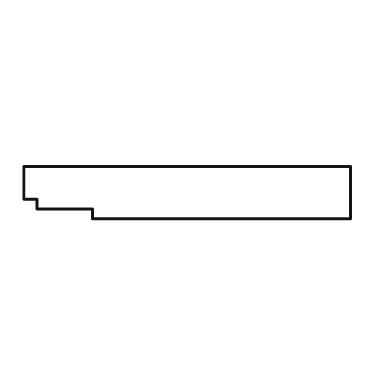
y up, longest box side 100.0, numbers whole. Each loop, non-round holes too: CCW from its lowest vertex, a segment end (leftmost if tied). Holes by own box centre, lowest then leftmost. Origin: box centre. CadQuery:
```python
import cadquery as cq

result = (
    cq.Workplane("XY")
    .moveTo(-29.0, -8.0)
    .lineTo(50.0, -8.0)
    .lineTo(50.0, 8.0)
    .lineTo(-50.0, 8.0)
    .lineTo(-50.0, -2.0)
    .lineTo(-46.0, -2.0)
    .lineTo(-46.0, -5.0)
    .lineTo(-29.0, -5.0)
    .close()
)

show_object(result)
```